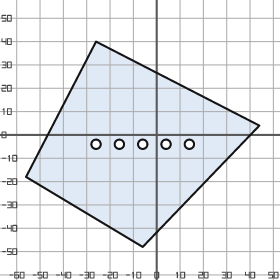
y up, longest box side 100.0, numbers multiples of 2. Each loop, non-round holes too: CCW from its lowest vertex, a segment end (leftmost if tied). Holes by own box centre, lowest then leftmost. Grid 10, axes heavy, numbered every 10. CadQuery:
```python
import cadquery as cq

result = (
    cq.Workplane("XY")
    .moveTo(-6.0, -48.0)
    .lineTo(44.0, 4.0)
    .lineTo(-26.0, 40.0)
    .lineTo(-56.0, -18.0)
    .close()
    .moveTo(-26.0, -4.0)
    .circle(2.0)
    .moveTo(-16.0, -4.0)
    .circle(2.0)
    .moveTo(-6.0, -4.0)
    .circle(2.0)
    .moveTo(4.0, -4.0)
    .circle(2.0)
    .moveTo(14.0, -4.0)
    .circle(2.0)
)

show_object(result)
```